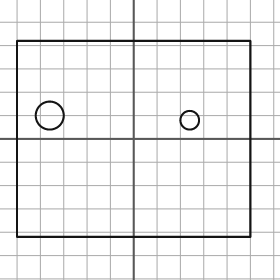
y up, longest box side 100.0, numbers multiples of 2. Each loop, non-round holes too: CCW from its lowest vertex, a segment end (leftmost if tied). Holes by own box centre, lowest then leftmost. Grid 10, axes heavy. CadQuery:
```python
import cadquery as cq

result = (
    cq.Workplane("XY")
    .moveTo(-50.0, -42.0)
    .lineTo(50.0, -42.0)
    .lineTo(50.0, 42.0)
    .lineTo(-50.0, 42.0)
    .close()
    .moveTo(24.0, 8.0)
    .circle(4.0)
    .moveTo(-36.0, 10.0)
    .circle(6.0)
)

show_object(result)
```